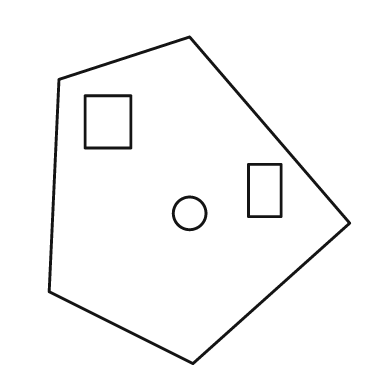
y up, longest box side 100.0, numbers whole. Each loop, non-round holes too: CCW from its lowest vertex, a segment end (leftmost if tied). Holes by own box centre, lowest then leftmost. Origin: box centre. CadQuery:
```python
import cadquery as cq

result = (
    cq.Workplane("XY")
    .moveTo(-2.0, -50.0)
    .lineTo(46.0, -7.0)
    .lineTo(-3.0, 50.0)
    .lineTo(-43.0, 37.0)
    .lineTo(-46.0, -28.0)
    .close()
    .moveTo(-3.0, -4.0)
    .circle(5.0)
    .moveTo(15.0, -5.0)
    .lineTo(25.0, -5.0)
    .lineTo(25.0, 11.0)
    .lineTo(15.0, 11.0)
    .close()
    .moveTo(-35.0, 16.0)
    .lineTo(-21.0, 16.0)
    .lineTo(-21.0, 32.0)
    .lineTo(-35.0, 32.0)
    .close()
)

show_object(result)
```